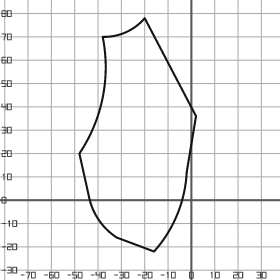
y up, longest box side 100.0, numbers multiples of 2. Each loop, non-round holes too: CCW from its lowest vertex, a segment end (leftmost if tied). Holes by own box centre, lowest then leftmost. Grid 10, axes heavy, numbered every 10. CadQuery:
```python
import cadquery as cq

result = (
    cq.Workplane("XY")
    .moveTo(-16.0, -22.0)
    .threePointArc((-6.0, -6.0), (-2.0, 12.0))
    .lineTo(2.0, 36.0)
    .lineTo(-20.0, 78.0)
    .threePointArc((-28.0, 72.0), (-38.0, 70.0))
    .threePointArc((-38.0, 44.0), (-48.0, 20.0))
    .lineTo(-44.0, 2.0)
    .threePointArc((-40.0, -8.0), (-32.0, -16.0))
    .close()
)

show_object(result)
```